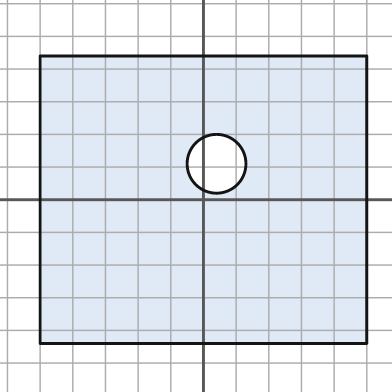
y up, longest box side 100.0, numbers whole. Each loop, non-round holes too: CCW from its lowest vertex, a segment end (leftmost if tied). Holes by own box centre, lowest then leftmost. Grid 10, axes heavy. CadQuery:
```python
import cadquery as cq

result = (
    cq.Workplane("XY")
    .moveTo(-50.0, -44.0)
    .lineTo(50.0, -44.0)
    .lineTo(50.0, 44.0)
    .lineTo(-50.0, 44.0)
    .close()
    .moveTo(4.0, 11.0)
    .circle(9.0)
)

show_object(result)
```